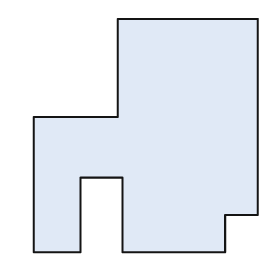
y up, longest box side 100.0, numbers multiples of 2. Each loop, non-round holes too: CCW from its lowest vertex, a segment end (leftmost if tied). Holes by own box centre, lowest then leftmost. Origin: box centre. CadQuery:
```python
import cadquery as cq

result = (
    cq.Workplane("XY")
    .moveTo(-48.0, -50.0)
    .lineTo(-28.0, -50.0)
    .lineTo(-28.0, -18.0)
    .lineTo(-10.0, -18.0)
    .lineTo(-10.0, -50.0)
    .lineTo(34.0, -50.0)
    .lineTo(34.0, -34.0)
    .lineTo(48.0, -34.0)
    .lineTo(48.0, 50.0)
    .lineTo(-12.0, 50.0)
    .lineTo(-12.0, 8.0)
    .lineTo(-48.0, 8.0)
    .close()
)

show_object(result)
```